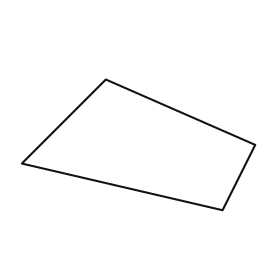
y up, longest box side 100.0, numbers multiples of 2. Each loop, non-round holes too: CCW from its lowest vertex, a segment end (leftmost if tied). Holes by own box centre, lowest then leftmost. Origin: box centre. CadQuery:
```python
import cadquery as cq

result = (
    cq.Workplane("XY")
    .moveTo(36.0, -28.0)
    .lineTo(50.0, 0.0)
    .lineTo(-14.0, 28.0)
    .lineTo(-50.0, -8.0)
    .close()
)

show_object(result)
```